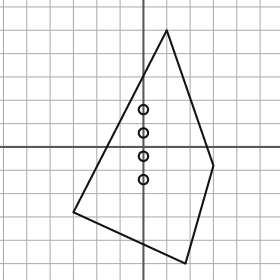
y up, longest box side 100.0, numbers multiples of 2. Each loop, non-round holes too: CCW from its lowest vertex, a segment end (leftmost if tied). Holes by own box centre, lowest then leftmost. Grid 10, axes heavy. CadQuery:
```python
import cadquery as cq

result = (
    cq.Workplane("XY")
    .moveTo(18.0, -50.0)
    .lineTo(30.0, -8.0)
    .lineTo(10.0, 50.0)
    .lineTo(-30.0, -28.0)
    .close()
    .moveTo(0.0, -14.0)
    .circle(2.0)
    .moveTo(0.0, -4.0)
    .circle(2.0)
    .moveTo(0.0, 6.0)
    .circle(2.0)
    .moveTo(0.0, 16.0)
    .circle(2.0)
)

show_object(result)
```